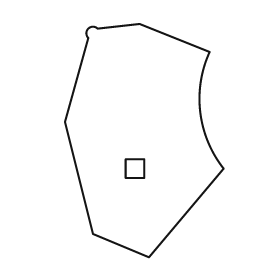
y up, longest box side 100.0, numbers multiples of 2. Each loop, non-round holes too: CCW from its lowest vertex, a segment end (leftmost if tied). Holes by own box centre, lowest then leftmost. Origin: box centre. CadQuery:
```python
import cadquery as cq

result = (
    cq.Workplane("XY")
    .moveTo(2.0, -50.0)
    .lineTo(34.0, -12.0)
    .threePointArc((24.0, 12.0), (28.0, 38.0))
    .lineTo(-2.0, 50.0)
    .lineTo(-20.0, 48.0)
    .threePointArc((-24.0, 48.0), (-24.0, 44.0))
    .lineTo(-34.0, 8.0)
    .lineTo(-22.0, -40.0)
    .close()
    .moveTo(-8.0, -16.0)
    .lineTo(0.0, -16.0)
    .lineTo(0.0, -8.0)
    .lineTo(-8.0, -8.0)
    .close()
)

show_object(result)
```